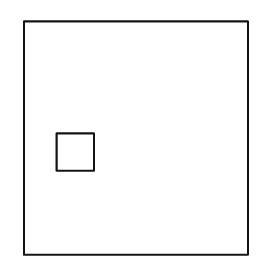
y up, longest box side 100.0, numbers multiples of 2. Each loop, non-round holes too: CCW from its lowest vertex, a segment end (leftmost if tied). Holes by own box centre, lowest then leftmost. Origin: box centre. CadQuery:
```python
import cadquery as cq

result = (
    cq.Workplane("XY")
    .moveTo(-48.0, -50.0)
    .lineTo(48.0, -50.0)
    .lineTo(48.0, 50.0)
    .lineTo(-48.0, 50.0)
    .close()
    .moveTo(-34.0, -14.0)
    .lineTo(-18.0, -14.0)
    .lineTo(-18.0, 2.0)
    .lineTo(-34.0, 2.0)
    .close()
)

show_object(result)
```